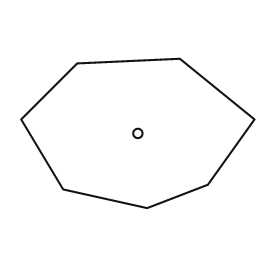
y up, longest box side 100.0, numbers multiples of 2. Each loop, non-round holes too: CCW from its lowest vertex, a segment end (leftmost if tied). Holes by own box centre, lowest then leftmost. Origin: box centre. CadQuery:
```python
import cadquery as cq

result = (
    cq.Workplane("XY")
    .moveTo(4.0, -32.0)
    .lineTo(30.0, -22.0)
    .lineTo(50.0, 6.0)
    .lineTo(18.0, 32.0)
    .lineTo(-26.0, 30.0)
    .lineTo(-50.0, 6.0)
    .lineTo(-32.0, -24.0)
    .close()
    .moveTo(0.0, 0.0)
    .circle(2.0)
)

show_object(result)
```